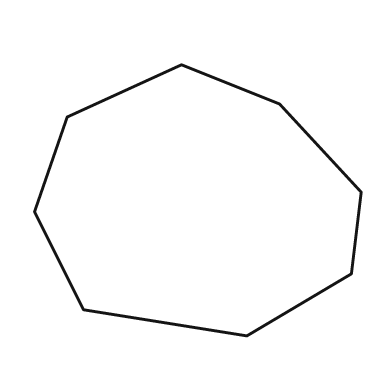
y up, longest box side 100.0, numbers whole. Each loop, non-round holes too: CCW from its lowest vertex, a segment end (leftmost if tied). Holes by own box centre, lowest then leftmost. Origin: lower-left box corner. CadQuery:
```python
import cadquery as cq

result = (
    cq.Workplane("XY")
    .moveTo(65.0, 0.0)
    .lineTo(97.0, 19.0)
    .lineTo(100.0, 44.0)
    .lineTo(75.0, 71.0)
    .lineTo(45.0, 83.0)
    .lineTo(10.0, 67.0)
    .lineTo(0.0, 38.0)
    .lineTo(15.0, 8.0)
    .close()
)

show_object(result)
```